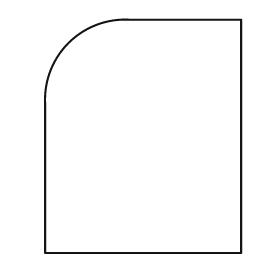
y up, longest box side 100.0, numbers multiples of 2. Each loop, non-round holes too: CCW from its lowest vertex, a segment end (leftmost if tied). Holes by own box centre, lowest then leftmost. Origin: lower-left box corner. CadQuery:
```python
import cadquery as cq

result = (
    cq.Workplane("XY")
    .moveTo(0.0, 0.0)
    .lineTo(84.0, 0.0)
    .lineTo(84.0, 100.0)
    .lineTo(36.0, 100.0)
    .threePointArc((10.0, 90.0), (0.0, 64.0))
    .close()
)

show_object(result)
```